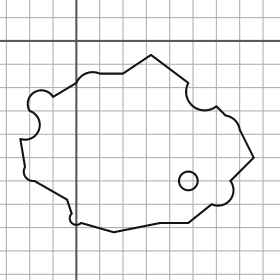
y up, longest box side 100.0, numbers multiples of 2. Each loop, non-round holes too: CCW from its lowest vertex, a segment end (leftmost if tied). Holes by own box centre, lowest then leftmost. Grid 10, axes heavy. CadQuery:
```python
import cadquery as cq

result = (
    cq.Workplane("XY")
    .moveTo(16.0, -82.0)
    .lineTo(36.0, -78.0)
    .lineTo(48.0, -78.0)
    .lineTo(58.0, -70.0)
    .threePointArc((66.0, -68.0), (66.0, -60.0))
    .lineTo(76.0, -50.0)
    .lineTo(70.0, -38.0)
    .threePointArc((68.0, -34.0), (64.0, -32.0))
    .lineTo(60.0, -28.0)
    .threePointArc((50.0, -28.0), (48.0, -18.0))
    .lineTo(32.0, -6.0)
    .lineTo(20.0, -14.0)
    .lineTo(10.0, -14.0)
    .threePointArc((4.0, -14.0), (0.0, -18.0))
    .lineTo(-10.0, -24.0)
    .threePointArc((-18.0, -22.0), (-20.0, -30.0))
    .threePointArc((-16.0, -38.0), (-24.0, -42.0))
    .lineTo(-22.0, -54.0)
    .threePointArc((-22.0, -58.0), (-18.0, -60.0))
    .lineTo(-4.0, -68.0)
    .lineTo(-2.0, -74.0)
    .threePointArc((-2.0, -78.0), (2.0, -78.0))
    .close()
    .moveTo(48.0, -60.0)
    .circle(4.0)
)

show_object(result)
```